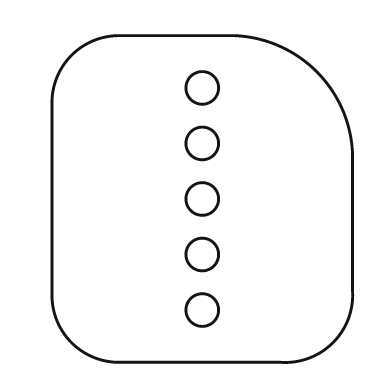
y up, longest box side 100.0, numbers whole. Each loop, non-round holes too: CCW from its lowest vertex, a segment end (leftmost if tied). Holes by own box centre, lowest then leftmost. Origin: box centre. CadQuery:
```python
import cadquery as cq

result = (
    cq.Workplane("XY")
    .moveTo(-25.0, -50.0)
    .lineTo(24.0, -50.0)
    .threePointArc((40.0, -44.0), (46.0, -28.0))
    .lineTo(46.0, 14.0)
    .threePointArc((35.0, 39.0), (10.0, 50.0))
    .lineTo(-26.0, 50.0)
    .threePointArc((-40.0, 44.0), (-46.0, 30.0))
    .lineTo(-46.0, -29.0)
    .threePointArc((-40.0, -44.0), (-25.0, -50.0))
    .close()
    .moveTo(0.0, -34.0)
    .circle(5.0)
    .moveTo(0.0, -17.0)
    .circle(5.0)
    .moveTo(0.0, 0.0)
    .circle(5.0)
    .moveTo(0.0, 17.0)
    .circle(5.0)
    .moveTo(0.0, 34.0)
    .circle(5.0)
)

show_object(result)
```